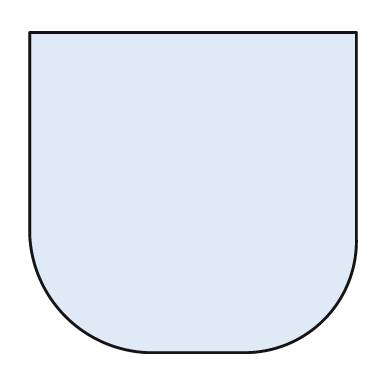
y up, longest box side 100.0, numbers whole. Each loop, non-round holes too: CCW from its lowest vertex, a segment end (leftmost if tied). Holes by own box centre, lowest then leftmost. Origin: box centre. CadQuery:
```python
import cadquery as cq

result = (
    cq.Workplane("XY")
    .moveTo(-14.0, -49.0)
    .lineTo(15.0, -49.0)
    .threePointArc((40.0, -39.0), (50.0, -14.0))
    .lineTo(50.0, 49.0)
    .lineTo(-50.0, 49.0)
    .lineTo(-50.0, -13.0)
    .threePointArc((-39.0, -38.0), (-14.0, -49.0))
    .close()
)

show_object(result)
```